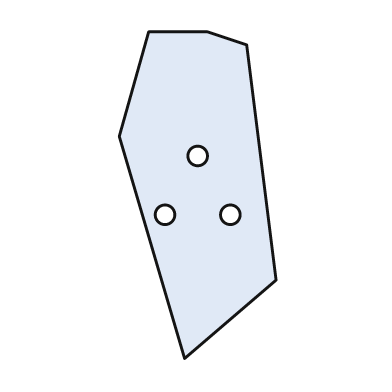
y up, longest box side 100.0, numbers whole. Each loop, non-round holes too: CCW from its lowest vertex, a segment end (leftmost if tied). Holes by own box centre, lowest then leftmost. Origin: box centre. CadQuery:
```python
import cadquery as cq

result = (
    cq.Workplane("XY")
    .moveTo(-4.0, -50.0)
    .lineTo(24.0, -26.0)
    .lineTo(15.0, 46.0)
    .lineTo(3.0, 50.0)
    .lineTo(-15.0, 50.0)
    .lineTo(-24.0, 18.0)
    .close()
    .moveTo(-10.0, -6.0)
    .circle(3.0)
    .moveTo(10.0, -6.0)
    .circle(3.0)
    .moveTo(0.0, 12.0)
    .circle(3.0)
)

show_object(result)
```